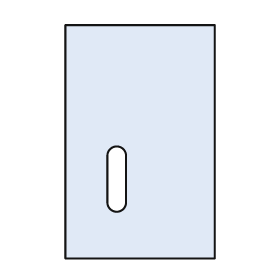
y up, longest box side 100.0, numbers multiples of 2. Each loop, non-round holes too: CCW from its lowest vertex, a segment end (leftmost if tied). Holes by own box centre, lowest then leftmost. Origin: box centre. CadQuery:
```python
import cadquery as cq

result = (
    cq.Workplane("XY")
    .moveTo(-32.0, -50.0)
    .lineTo(32.0, -50.0)
    .lineTo(32.0, 50.0)
    .lineTo(-32.0, 50.0)
    .close()
    .moveTo(-14.0, -26.0)
    .threePointArc((-10.0, -30.0), (-6.0, -26.0))
    .lineTo(-6.0, -6.0)
    .threePointArc((-10.0, -2.0), (-14.0, -6.0))
    .close()
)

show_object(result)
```